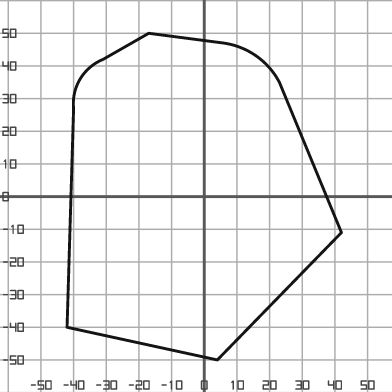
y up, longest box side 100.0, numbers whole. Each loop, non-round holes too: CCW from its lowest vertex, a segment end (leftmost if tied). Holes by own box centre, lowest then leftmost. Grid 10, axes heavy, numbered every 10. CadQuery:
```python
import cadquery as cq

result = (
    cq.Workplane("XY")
    .moveTo(4.0, -50.0)
    .lineTo(42.0, -11.0)
    .lineTo(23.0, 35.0)
    .threePointArc((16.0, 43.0), (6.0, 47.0))
    .lineTo(-17.0, 50.0)
    .lineTo(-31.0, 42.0)
    .threePointArc((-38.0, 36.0), (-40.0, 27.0))
    .lineTo(-42.0, -40.0)
    .close()
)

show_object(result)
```